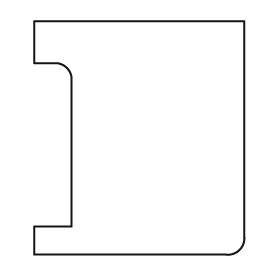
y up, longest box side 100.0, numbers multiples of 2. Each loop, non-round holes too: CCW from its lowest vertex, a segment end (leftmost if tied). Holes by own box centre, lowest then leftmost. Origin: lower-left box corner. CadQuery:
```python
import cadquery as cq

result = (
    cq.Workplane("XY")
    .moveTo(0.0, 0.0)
    .lineTo(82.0, 0.0)
    .threePointArc((88.0, 2.0), (90.0, 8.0))
    .lineTo(90.0, 100.0)
    .lineTo(0.0, 100.0)
    .lineTo(0.0, 82.0)
    .lineTo(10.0, 82.0)
    .threePointArc((14.0, 80.0), (16.0, 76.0))
    .lineTo(16.0, 12.0)
    .lineTo(0.0, 12.0)
    .close()
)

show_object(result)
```